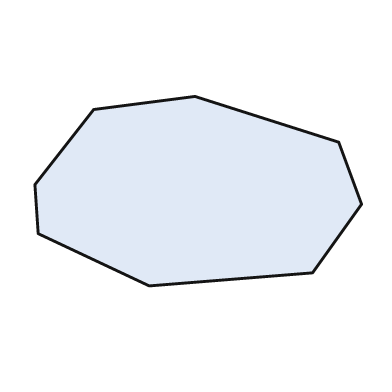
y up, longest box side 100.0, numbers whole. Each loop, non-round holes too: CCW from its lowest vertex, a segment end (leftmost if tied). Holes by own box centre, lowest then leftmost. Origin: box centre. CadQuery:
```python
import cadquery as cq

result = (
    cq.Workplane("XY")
    .moveTo(-15.0, -29.0)
    .lineTo(35.0, -25.0)
    .lineTo(50.0, -4.0)
    .lineTo(43.0, 15.0)
    .lineTo(-1.0, 29.0)
    .lineTo(-32.0, 25.0)
    .lineTo(-50.0, 2.0)
    .lineTo(-49.0, -13.0)
    .close()
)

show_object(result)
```